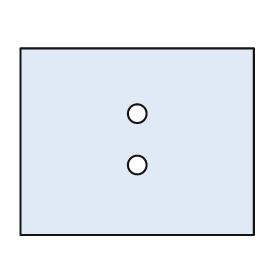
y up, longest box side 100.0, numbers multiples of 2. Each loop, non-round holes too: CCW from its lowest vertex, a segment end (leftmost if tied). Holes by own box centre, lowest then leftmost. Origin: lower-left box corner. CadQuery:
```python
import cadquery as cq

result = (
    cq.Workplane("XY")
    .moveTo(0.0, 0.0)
    .lineTo(100.0, 0.0)
    .lineTo(100.0, 80.0)
    .lineTo(0.0, 80.0)
    .close()
    .moveTo(50.0, 30.0)
    .circle(4.0)
    .moveTo(50.0, 52.0)
    .circle(4.0)
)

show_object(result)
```